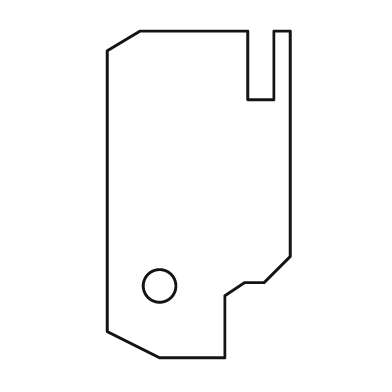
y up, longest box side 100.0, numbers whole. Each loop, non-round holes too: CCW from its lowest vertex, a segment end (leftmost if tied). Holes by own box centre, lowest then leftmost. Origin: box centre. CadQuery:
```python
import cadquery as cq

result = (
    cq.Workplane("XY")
    .moveTo(-12.0, -50.0)
    .lineTo(8.0, -50.0)
    .lineTo(8.0, -31.0)
    .lineTo(14.0, -27.0)
    .lineTo(20.0, -27.0)
    .lineTo(28.0, -19.0)
    .lineTo(28.0, 50.0)
    .lineTo(23.0, 50.0)
    .lineTo(23.0, 29.0)
    .lineTo(15.0, 29.0)
    .lineTo(15.0, 50.0)
    .lineTo(-18.0, 50.0)
    .lineTo(-28.0, 44.0)
    .lineTo(-28.0, -42.0)
    .close()
    .moveTo(-12.0, -28.0)
    .circle(5.0)
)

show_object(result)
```